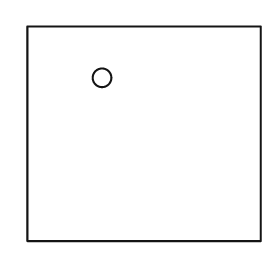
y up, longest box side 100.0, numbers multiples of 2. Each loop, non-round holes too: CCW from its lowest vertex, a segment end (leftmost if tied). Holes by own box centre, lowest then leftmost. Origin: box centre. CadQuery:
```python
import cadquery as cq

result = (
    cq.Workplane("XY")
    .moveTo(-50.0, -46.0)
    .lineTo(50.0, -46.0)
    .lineTo(50.0, 46.0)
    .lineTo(-50.0, 46.0)
    .close()
    .moveTo(-18.0, 24.0)
    .circle(4.0)
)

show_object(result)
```